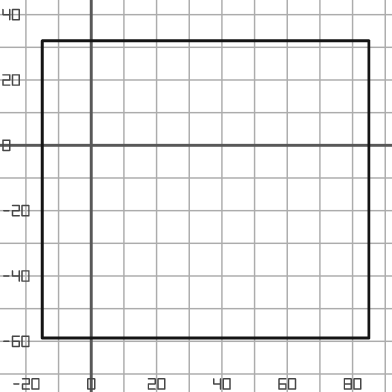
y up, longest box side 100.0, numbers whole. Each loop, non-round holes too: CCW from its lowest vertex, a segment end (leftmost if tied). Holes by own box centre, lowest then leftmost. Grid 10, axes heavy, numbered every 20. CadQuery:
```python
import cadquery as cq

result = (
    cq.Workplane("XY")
    .moveTo(-15.0, -59.0)
    .lineTo(85.0, -59.0)
    .lineTo(85.0, 32.0)
    .lineTo(-15.0, 32.0)
    .close()
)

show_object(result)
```